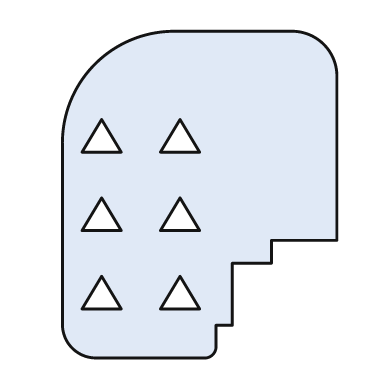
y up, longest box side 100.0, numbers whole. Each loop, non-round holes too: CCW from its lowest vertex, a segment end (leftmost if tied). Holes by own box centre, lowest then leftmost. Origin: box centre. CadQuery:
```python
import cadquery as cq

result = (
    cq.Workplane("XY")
    .moveTo(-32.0, -50.0)
    .lineTo(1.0, -50.0)
    .threePointArc((4.0, -49.0), (5.0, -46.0))
    .lineTo(5.0, -40.0)
    .lineTo(10.0, -40.0)
    .lineTo(10.0, -21.0)
    .lineTo(22.0, -21.0)
    .lineTo(22.0, -14.0)
    .lineTo(42.0, -14.0)
    .lineTo(42.0, 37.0)
    .threePointArc((38.0, 46.0), (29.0, 50.0))
    .lineTo(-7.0, 50.0)
    .threePointArc((-32.0, 40.0), (-42.0, 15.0))
    .lineTo(-42.0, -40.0)
    .threePointArc((-39.0, -47.0), (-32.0, -50.0))
    .close()
    .moveTo(-36.0, -35.0)
    .lineTo(-24.0, -35.0)
    .lineTo(-30.0, -25.0)
    .close()
    .moveTo(-12.0, -35.0)
    .lineTo(0.0, -35.0)
    .lineTo(-6.0, -25.0)
    .close()
    .moveTo(-36.0, -11.0)
    .lineTo(-24.0, -11.0)
    .lineTo(-30.0, -1.0)
    .close()
    .moveTo(-12.0, -11.0)
    .lineTo(0.0, -11.0)
    .lineTo(-6.0, -1.0)
    .close()
    .moveTo(-36.0, 13.0)
    .lineTo(-24.0, 13.0)
    .lineTo(-30.0, 23.0)
    .close()
    .moveTo(-12.0, 13.0)
    .lineTo(0.0, 13.0)
    .lineTo(-6.0, 23.0)
    .close()
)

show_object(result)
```